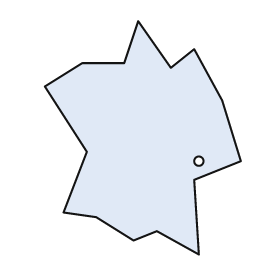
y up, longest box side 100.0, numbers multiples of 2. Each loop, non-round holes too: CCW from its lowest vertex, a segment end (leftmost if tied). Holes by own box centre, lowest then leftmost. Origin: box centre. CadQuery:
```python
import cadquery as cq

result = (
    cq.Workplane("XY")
    .moveTo(24.0, -50.0)
    .lineTo(22.0, -18.0)
    .lineTo(42.0, -10.0)
    .lineTo(34.0, 16.0)
    .lineTo(22.0, 38.0)
    .lineTo(12.0, 30.0)
    .lineTo(-2.0, 50.0)
    .lineTo(-8.0, 32.0)
    .lineTo(-26.0, 32.0)
    .lineTo(-42.0, 22.0)
    .lineTo(-24.0, -6.0)
    .lineTo(-34.0, -32.0)
    .lineTo(-20.0, -34.0)
    .lineTo(-4.0, -44.0)
    .lineTo(6.0, -40.0)
    .close()
    .moveTo(24.0, -10.0)
    .circle(2.0)
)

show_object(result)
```